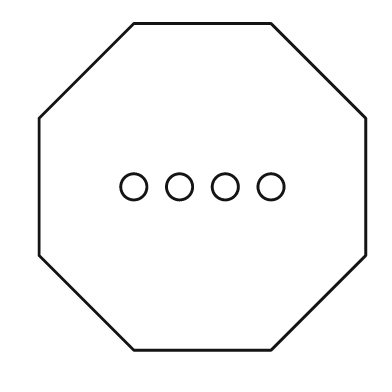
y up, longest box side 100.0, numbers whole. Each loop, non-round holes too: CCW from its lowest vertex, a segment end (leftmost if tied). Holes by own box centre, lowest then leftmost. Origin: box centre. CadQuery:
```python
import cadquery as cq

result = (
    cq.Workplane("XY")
    .moveTo(-21.0, -50.0)
    .lineTo(21.0, -50.0)
    .lineTo(50.0, -21.0)
    .lineTo(50.0, 21.0)
    .lineTo(21.0, 50.0)
    .lineTo(-21.0, 50.0)
    .lineTo(-50.0, 21.0)
    .lineTo(-50.0, -21.0)
    .close()
    .moveTo(-21.0, 0.0)
    .circle(4.0)
    .moveTo(-7.0, 0.0)
    .circle(4.0)
    .moveTo(7.0, 0.0)
    .circle(4.0)
    .moveTo(21.0, 0.0)
    .circle(4.0)
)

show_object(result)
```